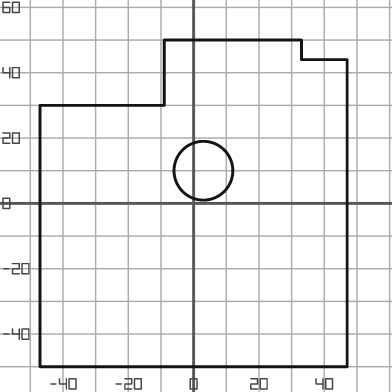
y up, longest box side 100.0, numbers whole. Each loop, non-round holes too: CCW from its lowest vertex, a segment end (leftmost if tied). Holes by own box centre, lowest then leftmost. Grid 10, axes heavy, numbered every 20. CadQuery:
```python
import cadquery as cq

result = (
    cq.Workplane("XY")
    .moveTo(-47.0, -50.0)
    .lineTo(47.0, -50.0)
    .lineTo(47.0, 44.0)
    .lineTo(33.0, 44.0)
    .lineTo(33.0, 50.0)
    .lineTo(-9.0, 50.0)
    .lineTo(-9.0, 30.0)
    .lineTo(-47.0, 30.0)
    .close()
    .moveTo(3.0, 10.0)
    .circle(9.0)
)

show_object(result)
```